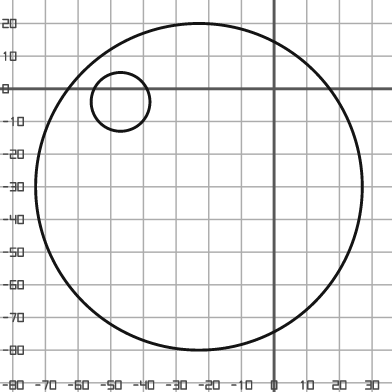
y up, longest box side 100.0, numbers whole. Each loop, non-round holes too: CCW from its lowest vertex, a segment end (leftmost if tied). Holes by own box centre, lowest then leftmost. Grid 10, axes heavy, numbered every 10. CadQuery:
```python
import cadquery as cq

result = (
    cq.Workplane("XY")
    .moveTo(-23.0, -30.0)
    .circle(50.0)
    .moveTo(-47.0, -4.0)
    .circle(9.0)
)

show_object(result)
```